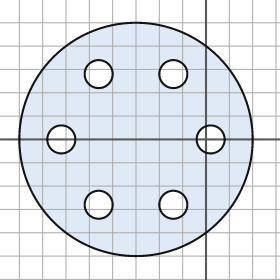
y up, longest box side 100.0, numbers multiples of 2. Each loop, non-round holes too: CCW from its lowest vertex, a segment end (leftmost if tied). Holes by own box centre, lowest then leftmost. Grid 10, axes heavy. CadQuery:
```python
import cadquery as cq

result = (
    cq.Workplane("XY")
    .moveTo(-30.0, 0.0)
    .circle(50.0)
    .moveTo(-46.0, -28.0)
    .circle(6.0)
    .moveTo(-14.0, -28.0)
    .circle(6.0)
    .moveTo(-62.0, 0.0)
    .circle(6.0)
    .moveTo(2.0, 0.0)
    .circle(6.0)
    .moveTo(-46.0, 28.0)
    .circle(6.0)
    .moveTo(-14.0, 28.0)
    .circle(6.0)
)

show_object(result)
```